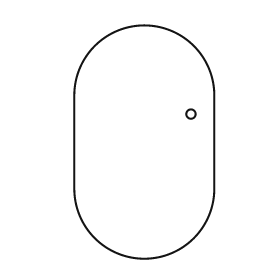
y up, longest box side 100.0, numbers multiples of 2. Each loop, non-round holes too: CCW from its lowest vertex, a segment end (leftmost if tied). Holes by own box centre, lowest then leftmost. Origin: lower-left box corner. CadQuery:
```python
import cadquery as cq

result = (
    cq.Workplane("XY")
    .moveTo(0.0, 30.0)
    .threePointArc((30.0, 0.0), (60.0, 30.0))
    .lineTo(60.0, 70.0)
    .threePointArc((30.0, 100.0), (0.0, 70.0))
    .close()
    .moveTo(50.0, 62.0)
    .circle(2.0)
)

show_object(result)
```